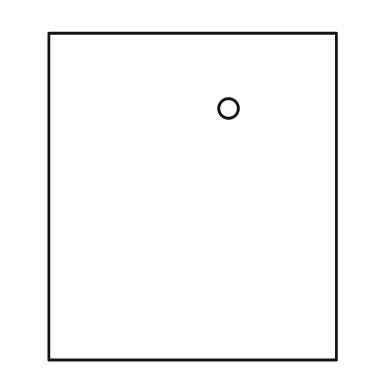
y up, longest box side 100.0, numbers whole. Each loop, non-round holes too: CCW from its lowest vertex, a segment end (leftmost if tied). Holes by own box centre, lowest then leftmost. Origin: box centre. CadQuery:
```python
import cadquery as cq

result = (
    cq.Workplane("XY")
    .moveTo(-44.0, -50.0)
    .lineTo(44.0, -50.0)
    .lineTo(44.0, 50.0)
    .lineTo(-44.0, 50.0)
    .close()
    .moveTo(11.0, 27.0)
    .circle(3.0)
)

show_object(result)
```